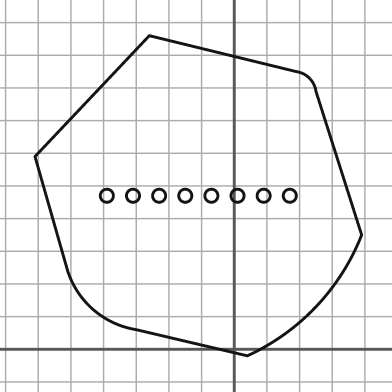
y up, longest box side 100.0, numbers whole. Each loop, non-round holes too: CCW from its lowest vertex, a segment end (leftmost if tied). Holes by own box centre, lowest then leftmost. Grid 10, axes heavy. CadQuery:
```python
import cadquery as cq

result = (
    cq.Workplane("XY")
    .moveTo(4.0, -2.0)
    .threePointArc((25.0, 13.0), (39.0, 35.0))
    .lineTo(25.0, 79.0)
    .threePointArc((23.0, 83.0), (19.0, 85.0))
    .lineTo(-26.0, 96.0)
    .lineTo(-61.0, 59.0)
    .lineTo(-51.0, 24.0)
    .threePointArc((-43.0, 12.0), (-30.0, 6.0))
    .close()
    .moveTo(-39.0, 47.0)
    .circle(2.0)
    .moveTo(-31.0, 47.0)
    .circle(2.0)
    .moveTo(-23.0, 47.0)
    .circle(2.0)
    .moveTo(-15.0, 47.0)
    .circle(2.0)
    .moveTo(-7.0, 47.0)
    .circle(2.0)
    .moveTo(1.0, 47.0)
    .circle(2.0)
    .moveTo(9.0, 47.0)
    .circle(2.0)
    .moveTo(17.0, 47.0)
    .circle(2.0)
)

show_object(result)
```